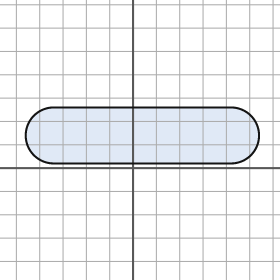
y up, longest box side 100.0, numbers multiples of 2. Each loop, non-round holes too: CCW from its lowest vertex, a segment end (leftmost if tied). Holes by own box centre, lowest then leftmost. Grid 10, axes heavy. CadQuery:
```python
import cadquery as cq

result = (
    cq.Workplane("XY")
    .moveTo(-34.0, 2.0)
    .lineTo(42.0, 2.0)
    .threePointArc((54.0, 14.0), (42.0, 26.0))
    .lineTo(-34.0, 26.0)
    .threePointArc((-46.0, 14.0), (-34.0, 2.0))
    .close()
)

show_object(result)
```